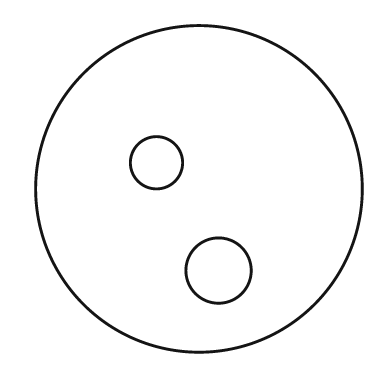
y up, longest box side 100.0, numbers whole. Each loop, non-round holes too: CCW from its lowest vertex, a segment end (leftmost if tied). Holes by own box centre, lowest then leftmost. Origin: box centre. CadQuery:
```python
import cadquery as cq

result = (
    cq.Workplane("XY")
    .moveTo(0.0, 0.0)
    .circle(50.0)
    .moveTo(6.0, -25.0)
    .circle(10.0)
    .moveTo(-13.0, 8.0)
    .circle(8.0)
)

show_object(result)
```